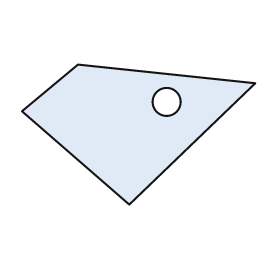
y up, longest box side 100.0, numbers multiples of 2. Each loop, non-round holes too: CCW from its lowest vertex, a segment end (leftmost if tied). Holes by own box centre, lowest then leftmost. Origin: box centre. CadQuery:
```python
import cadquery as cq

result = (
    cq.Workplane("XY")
    .moveTo(-4.0, -30.0)
    .lineTo(50.0, 22.0)
    .lineTo(-26.0, 30.0)
    .lineTo(-50.0, 10.0)
    .close()
    .moveTo(12.0, 14.0)
    .circle(6.0)
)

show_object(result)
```